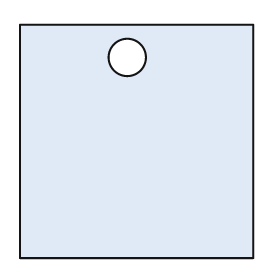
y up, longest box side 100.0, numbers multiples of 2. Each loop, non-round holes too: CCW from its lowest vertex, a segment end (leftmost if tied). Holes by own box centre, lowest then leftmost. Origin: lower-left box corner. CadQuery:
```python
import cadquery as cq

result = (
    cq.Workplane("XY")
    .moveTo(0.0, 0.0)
    .lineTo(100.0, 0.0)
    .lineTo(100.0, 100.0)
    .lineTo(0.0, 100.0)
    .close()
    .moveTo(46.0, 86.0)
    .circle(8.0)
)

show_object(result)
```